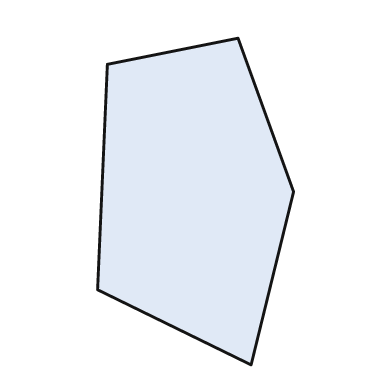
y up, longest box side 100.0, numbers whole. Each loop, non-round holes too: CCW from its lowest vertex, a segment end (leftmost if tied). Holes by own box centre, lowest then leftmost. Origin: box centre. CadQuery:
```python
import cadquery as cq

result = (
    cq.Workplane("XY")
    .moveTo(17.0, -50.0)
    .lineTo(30.0, 3.0)
    .lineTo(13.0, 50.0)
    .lineTo(-27.0, 42.0)
    .lineTo(-30.0, -27.0)
    .close()
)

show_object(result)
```